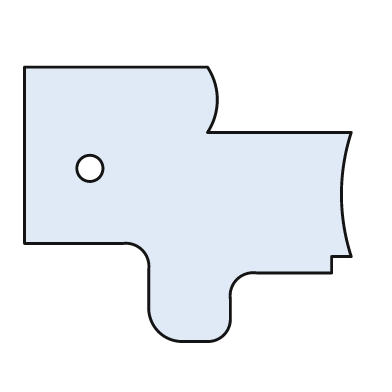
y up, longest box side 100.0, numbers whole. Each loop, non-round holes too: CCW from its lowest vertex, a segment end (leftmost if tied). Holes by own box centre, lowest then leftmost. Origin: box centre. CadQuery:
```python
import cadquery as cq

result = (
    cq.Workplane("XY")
    .moveTo(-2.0, -42.0)
    .lineTo(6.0, -42.0)
    .threePointArc((11.0, -40.0), (13.0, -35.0))
    .lineTo(13.0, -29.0)
    .threePointArc((15.0, -23.0), (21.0, -21.0))
    .lineTo(44.0, -21.0)
    .lineTo(44.0, -16.0)
    .lineTo(50.0, -16.0)
    .threePointArc((47.0, 3.0), (50.0, 22.0))
    .lineTo(6.0, 22.0)
    .threePointArc((9.0, 32.0), (6.0, 42.0))
    .lineTo(-50.0, 42.0)
    .lineTo(-50.0, -12.0)
    .lineTo(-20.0, -12.0)
    .threePointArc((-14.0, -14.0), (-12.0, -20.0))
    .lineTo(-12.0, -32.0)
    .threePointArc((-9.0, -39.0), (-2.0, -42.0))
    .close()
    .moveTo(-30.0, 11.0)
    .circle(4.0)
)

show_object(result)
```